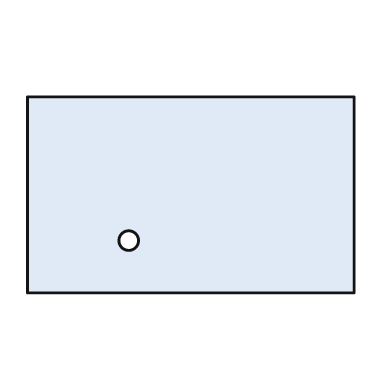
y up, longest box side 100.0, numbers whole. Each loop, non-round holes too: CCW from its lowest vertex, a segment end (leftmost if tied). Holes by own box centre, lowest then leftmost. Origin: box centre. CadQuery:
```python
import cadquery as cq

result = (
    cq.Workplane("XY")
    .moveTo(-50.0, -30.0)
    .lineTo(50.0, -30.0)
    .lineTo(50.0, 30.0)
    .lineTo(-50.0, 30.0)
    .close()
    .moveTo(-19.0, -14.0)
    .circle(3.0)
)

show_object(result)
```